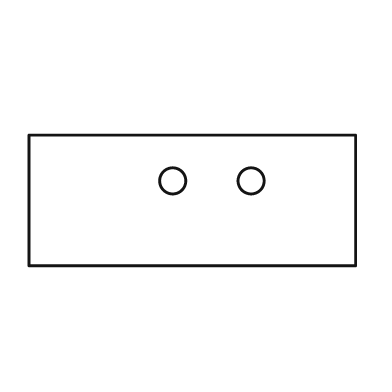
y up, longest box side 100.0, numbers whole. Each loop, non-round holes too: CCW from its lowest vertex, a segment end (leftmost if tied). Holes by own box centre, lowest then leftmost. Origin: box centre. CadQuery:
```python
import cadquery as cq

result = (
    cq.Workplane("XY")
    .moveTo(-50.0, -20.0)
    .lineTo(50.0, -20.0)
    .lineTo(50.0, 20.0)
    .lineTo(-50.0, 20.0)
    .close()
    .moveTo(-6.0, 6.0)
    .circle(4.0)
    .moveTo(18.0, 6.0)
    .circle(4.0)
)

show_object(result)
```